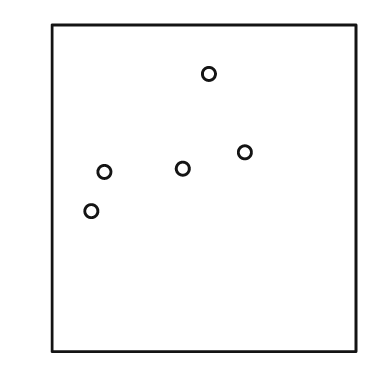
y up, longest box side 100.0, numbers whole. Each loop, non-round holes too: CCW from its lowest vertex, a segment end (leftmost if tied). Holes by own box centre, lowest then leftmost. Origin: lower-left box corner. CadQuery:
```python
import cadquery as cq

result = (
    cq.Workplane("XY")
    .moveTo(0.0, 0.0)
    .lineTo(93.0, 0.0)
    .lineTo(93.0, 100.0)
    .lineTo(0.0, 100.0)
    .close()
    .moveTo(12.0, 43.0)
    .circle(2.0)
    .moveTo(16.0, 55.0)
    .circle(2.0)
    .moveTo(40.0, 56.0)
    .circle(2.0)
    .moveTo(59.0, 61.0)
    .circle(2.0)
    .moveTo(48.0, 85.0)
    .circle(2.0)
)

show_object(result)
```